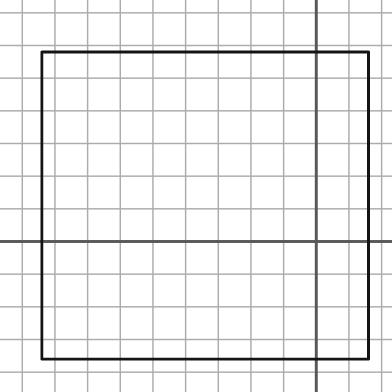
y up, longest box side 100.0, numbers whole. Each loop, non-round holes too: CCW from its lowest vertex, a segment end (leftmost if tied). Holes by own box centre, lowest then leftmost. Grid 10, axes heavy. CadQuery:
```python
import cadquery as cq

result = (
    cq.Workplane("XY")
    .moveTo(-84.0, -36.0)
    .lineTo(16.0, -36.0)
    .lineTo(16.0, 58.0)
    .lineTo(-84.0, 58.0)
    .close()
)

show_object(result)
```